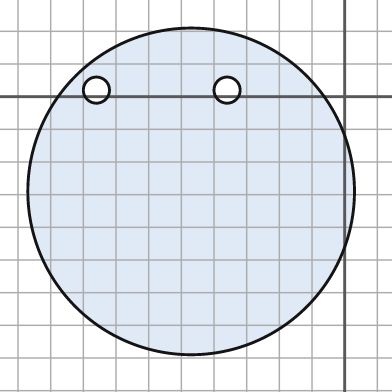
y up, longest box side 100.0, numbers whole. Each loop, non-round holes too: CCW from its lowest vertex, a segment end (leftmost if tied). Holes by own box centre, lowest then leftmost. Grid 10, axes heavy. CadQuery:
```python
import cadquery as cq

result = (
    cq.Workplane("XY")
    .moveTo(-47.0, -29.0)
    .circle(50.0)
    .moveTo(-76.0, 2.0)
    .circle(4.0)
    .moveTo(-36.0, 2.0)
    .circle(4.0)
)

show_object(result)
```